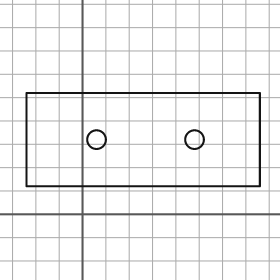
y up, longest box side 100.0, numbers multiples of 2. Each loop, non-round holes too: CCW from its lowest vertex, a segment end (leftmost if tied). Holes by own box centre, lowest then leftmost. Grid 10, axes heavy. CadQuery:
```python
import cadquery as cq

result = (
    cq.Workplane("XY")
    .moveTo(-24.0, 12.0)
    .lineTo(76.0, 12.0)
    .lineTo(76.0, 52.0)
    .lineTo(-24.0, 52.0)
    .close()
    .moveTo(6.0, 32.0)
    .circle(4.0)
    .moveTo(48.0, 32.0)
    .circle(4.0)
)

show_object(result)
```